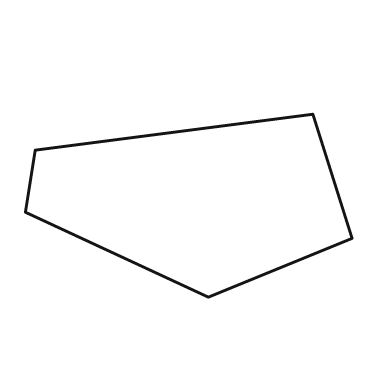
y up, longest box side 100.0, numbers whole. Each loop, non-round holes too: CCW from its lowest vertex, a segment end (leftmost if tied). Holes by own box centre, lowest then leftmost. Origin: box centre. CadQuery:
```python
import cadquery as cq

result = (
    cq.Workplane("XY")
    .moveTo(6.0, -28.0)
    .lineTo(50.0, -10.0)
    .lineTo(38.0, 28.0)
    .lineTo(-47.0, 17.0)
    .lineTo(-50.0, -2.0)
    .close()
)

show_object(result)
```